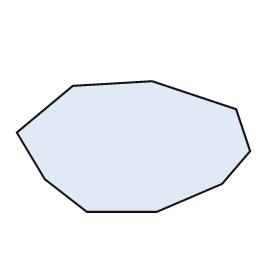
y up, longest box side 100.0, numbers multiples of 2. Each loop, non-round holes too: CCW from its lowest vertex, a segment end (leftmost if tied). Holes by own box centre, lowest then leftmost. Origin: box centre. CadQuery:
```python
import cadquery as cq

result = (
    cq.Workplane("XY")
    .moveTo(-20.0, -28.0)
    .lineTo(10.0, -28.0)
    .lineTo(38.0, -16.0)
    .lineTo(50.0, -2.0)
    .lineTo(44.0, 16.0)
    .lineTo(8.0, 28.0)
    .lineTo(-26.0, 26.0)
    .lineTo(-50.0, 6.0)
    .lineTo(-38.0, -14.0)
    .close()
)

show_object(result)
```